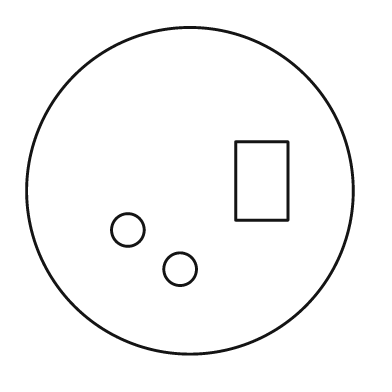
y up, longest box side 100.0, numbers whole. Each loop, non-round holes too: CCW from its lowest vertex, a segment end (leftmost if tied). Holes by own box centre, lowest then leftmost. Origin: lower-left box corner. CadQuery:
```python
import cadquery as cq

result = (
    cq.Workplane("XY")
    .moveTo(50.0, 50.0)
    .circle(50.0)
    .moveTo(47.0, 26.0)
    .circle(5.0)
    .moveTo(31.0, 38.0)
    .circle(5.0)
    .moveTo(64.0, 41.0)
    .lineTo(80.0, 41.0)
    .lineTo(80.0, 65.0)
    .lineTo(64.0, 65.0)
    .close()
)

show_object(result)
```